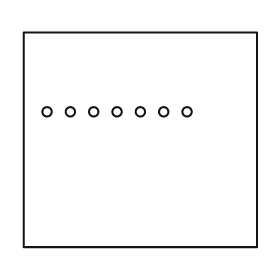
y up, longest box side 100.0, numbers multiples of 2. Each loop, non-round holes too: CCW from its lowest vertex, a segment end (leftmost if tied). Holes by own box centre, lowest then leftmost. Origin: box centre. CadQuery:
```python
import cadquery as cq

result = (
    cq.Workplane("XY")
    .moveTo(-50.0, -46.0)
    .lineTo(50.0, -46.0)
    .lineTo(50.0, 46.0)
    .lineTo(-50.0, 46.0)
    .close()
    .moveTo(-40.0, 12.0)
    .circle(2.0)
    .moveTo(-30.0, 12.0)
    .circle(2.0)
    .moveTo(-20.0, 12.0)
    .circle(2.0)
    .moveTo(-10.0, 12.0)
    .circle(2.0)
    .moveTo(0.0, 12.0)
    .circle(2.0)
    .moveTo(10.0, 12.0)
    .circle(2.0)
    .moveTo(20.0, 12.0)
    .circle(2.0)
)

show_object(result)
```